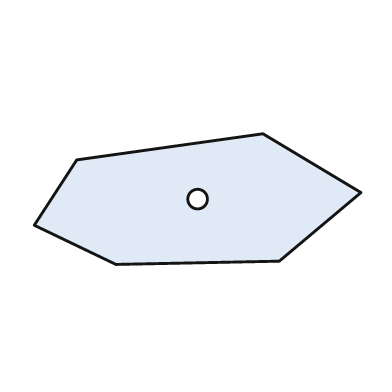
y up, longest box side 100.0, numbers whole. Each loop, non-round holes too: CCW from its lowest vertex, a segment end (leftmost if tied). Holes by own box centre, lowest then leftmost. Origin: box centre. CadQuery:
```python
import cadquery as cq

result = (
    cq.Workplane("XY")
    .moveTo(-25.0, -20.0)
    .lineTo(25.0, -19.0)
    .lineTo(50.0, 2.0)
    .lineTo(20.0, 20.0)
    .lineTo(-37.0, 12.0)
    .lineTo(-50.0, -8.0)
    .close()
    .moveTo(0.0, 0.0)
    .circle(3.0)
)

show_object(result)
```